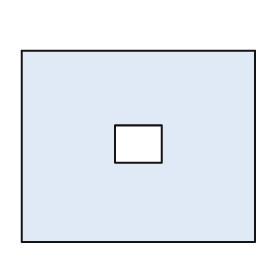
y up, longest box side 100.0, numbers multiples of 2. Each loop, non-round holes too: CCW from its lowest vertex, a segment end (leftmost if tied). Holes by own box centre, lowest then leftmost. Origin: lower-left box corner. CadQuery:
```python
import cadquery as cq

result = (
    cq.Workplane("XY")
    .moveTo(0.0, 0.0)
    .lineTo(100.0, 0.0)
    .lineTo(100.0, 82.0)
    .lineTo(0.0, 82.0)
    .close()
    .moveTo(40.0, 34.0)
    .lineTo(60.0, 34.0)
    .lineTo(60.0, 50.0)
    .lineTo(40.0, 50.0)
    .close()
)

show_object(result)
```